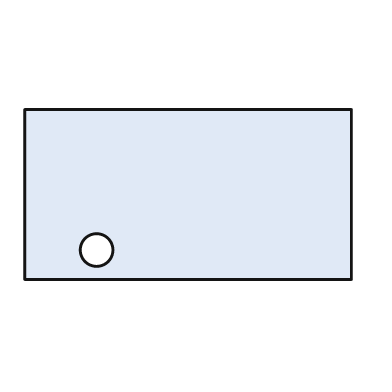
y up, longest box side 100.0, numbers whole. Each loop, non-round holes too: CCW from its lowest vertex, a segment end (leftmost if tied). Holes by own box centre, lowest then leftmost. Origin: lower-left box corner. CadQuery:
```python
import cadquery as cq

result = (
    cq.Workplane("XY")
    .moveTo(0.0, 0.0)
    .lineTo(100.0, 0.0)
    .lineTo(100.0, 52.0)
    .lineTo(0.0, 52.0)
    .close()
    .moveTo(22.0, 9.0)
    .circle(5.0)
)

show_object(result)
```